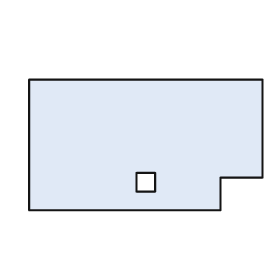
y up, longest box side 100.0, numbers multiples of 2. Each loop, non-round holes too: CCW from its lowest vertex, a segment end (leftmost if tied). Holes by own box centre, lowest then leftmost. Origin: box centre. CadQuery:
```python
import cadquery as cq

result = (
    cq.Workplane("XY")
    .moveTo(-50.0, -28.0)
    .lineTo(32.0, -28.0)
    .lineTo(32.0, -14.0)
    .lineTo(50.0, -14.0)
    .lineTo(50.0, 28.0)
    .lineTo(-50.0, 28.0)
    .close()
    .moveTo(-4.0, -20.0)
    .lineTo(4.0, -20.0)
    .lineTo(4.0, -12.0)
    .lineTo(-4.0, -12.0)
    .close()
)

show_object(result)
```